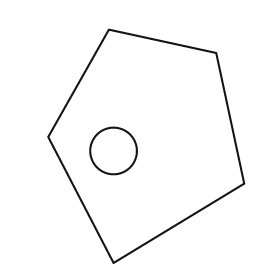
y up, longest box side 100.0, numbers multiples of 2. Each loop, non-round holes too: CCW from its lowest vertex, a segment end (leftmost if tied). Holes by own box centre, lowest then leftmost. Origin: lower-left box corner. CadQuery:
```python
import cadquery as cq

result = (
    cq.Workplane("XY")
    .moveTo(28.0, 0.0)
    .lineTo(84.0, 34.0)
    .lineTo(72.0, 90.0)
    .lineTo(26.0, 100.0)
    .lineTo(0.0, 54.0)
    .close()
    .moveTo(28.0, 48.0)
    .circle(10.0)
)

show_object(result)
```